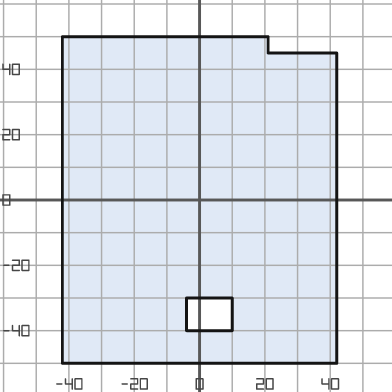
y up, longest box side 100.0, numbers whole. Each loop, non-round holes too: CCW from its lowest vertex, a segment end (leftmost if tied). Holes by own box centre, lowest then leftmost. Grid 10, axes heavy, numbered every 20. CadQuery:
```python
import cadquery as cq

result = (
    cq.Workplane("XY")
    .moveTo(-42.0, -50.0)
    .lineTo(42.0, -50.0)
    .lineTo(42.0, 45.0)
    .lineTo(21.0, 45.0)
    .lineTo(21.0, 50.0)
    .lineTo(-42.0, 50.0)
    .close()
    .moveTo(-4.0, -40.0)
    .lineTo(10.0, -40.0)
    .lineTo(10.0, -30.0)
    .lineTo(-4.0, -30.0)
    .close()
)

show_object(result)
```